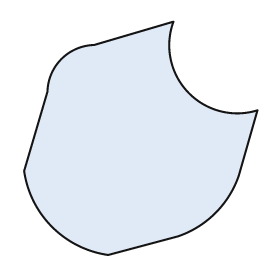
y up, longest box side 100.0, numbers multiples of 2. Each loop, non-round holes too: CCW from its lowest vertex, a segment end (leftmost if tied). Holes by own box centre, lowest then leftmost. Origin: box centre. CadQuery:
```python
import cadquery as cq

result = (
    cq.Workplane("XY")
    .moveTo(-14.0, -50.0)
    .lineTo(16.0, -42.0)
    .threePointArc((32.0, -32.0), (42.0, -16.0))
    .lineTo(50.0, 12.0)
    .threePointArc((20.0, 20.0), (14.0, 50.0))
    .lineTo(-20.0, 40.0)
    .threePointArc((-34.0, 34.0), (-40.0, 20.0))
    .lineTo(-50.0, -14.0)
    .threePointArc((-38.0, -38.0), (-14.0, -50.0))
    .close()
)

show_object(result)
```